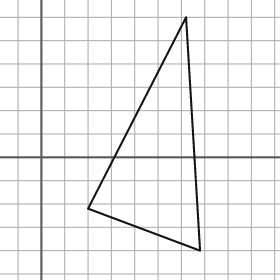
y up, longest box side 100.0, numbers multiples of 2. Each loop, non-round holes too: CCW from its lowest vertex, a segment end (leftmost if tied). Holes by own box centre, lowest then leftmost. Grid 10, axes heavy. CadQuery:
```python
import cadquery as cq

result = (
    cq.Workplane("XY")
    .moveTo(68.0, -40.0)
    .lineTo(62.0, 60.0)
    .lineTo(20.0, -22.0)
    .close()
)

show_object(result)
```